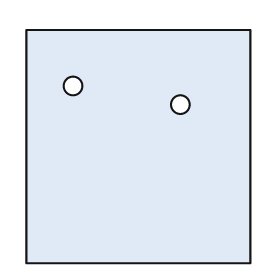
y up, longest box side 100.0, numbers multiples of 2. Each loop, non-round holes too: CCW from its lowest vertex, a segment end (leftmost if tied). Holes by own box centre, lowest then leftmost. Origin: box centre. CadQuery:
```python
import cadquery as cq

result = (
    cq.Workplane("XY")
    .moveTo(-48.0, -50.0)
    .lineTo(48.0, -50.0)
    .lineTo(48.0, 50.0)
    .lineTo(-48.0, 50.0)
    .close()
    .moveTo(18.0, 18.0)
    .circle(4.0)
    .moveTo(-28.0, 26.0)
    .circle(4.0)
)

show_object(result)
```